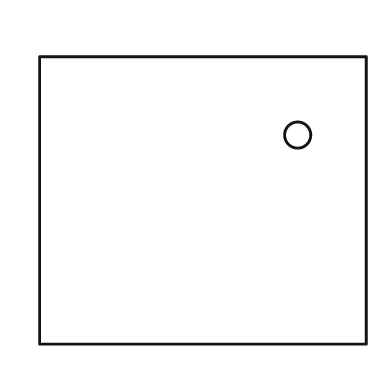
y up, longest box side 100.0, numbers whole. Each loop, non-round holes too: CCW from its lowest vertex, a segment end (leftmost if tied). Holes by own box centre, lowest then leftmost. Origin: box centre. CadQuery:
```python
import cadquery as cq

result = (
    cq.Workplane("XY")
    .moveTo(-50.0, -44.0)
    .lineTo(50.0, -44.0)
    .lineTo(50.0, 44.0)
    .lineTo(-50.0, 44.0)
    .close()
    .moveTo(29.0, 20.0)
    .circle(4.0)
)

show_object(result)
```